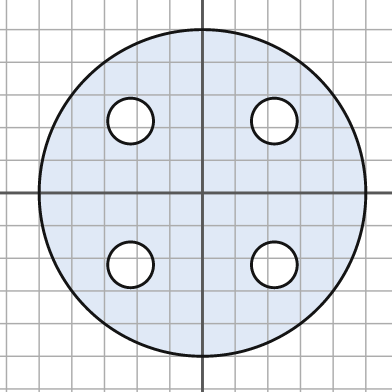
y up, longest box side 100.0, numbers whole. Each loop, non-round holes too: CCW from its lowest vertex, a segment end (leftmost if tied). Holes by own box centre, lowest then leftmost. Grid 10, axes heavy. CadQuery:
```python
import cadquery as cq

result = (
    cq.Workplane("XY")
    .moveTo(0.0, 0.0)
    .circle(50.0)
    .moveTo(-22.0, -22.0)
    .circle(7.0)
    .moveTo(22.0, -22.0)
    .circle(7.0)
    .moveTo(-22.0, 22.0)
    .circle(7.0)
    .moveTo(22.0, 22.0)
    .circle(7.0)
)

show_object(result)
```